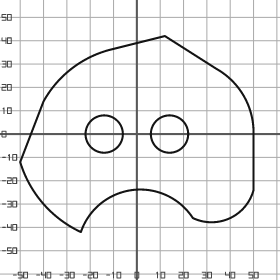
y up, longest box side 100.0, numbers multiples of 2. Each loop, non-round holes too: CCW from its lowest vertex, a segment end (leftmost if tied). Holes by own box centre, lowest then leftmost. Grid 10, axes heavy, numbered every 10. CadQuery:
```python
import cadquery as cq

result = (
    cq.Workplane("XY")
    .moveTo(-24.0, -42.0)
    .threePointArc((-2.0, -24.0), (24.0, -36.0))
    .threePointArc((40.0, -36.0), (50.0, -24.0))
    .lineTo(50.0, 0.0)
    .threePointArc((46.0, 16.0), (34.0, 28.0))
    .lineTo(12.0, 42.0)
    .lineTo(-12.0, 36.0)
    .threePointArc((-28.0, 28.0), (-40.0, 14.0))
    .lineTo(-50.0, -12.0)
    .threePointArc((-40.0, -30.0), (-24.0, -42.0))
    .close()
    .moveTo(-14.0, 0.0)
    .circle(8.0)
    .moveTo(14.0, 0.0)
    .circle(8.0)
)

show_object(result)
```